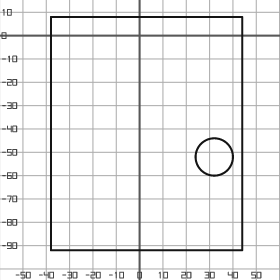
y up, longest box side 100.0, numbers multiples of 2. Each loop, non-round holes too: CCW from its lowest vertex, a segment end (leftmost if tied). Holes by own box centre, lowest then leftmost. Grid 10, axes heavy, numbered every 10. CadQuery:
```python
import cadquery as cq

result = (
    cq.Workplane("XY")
    .moveTo(-38.0, -92.0)
    .lineTo(44.0, -92.0)
    .lineTo(44.0, 8.0)
    .lineTo(-38.0, 8.0)
    .close()
    .moveTo(32.0, -52.0)
    .circle(8.0)
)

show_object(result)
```